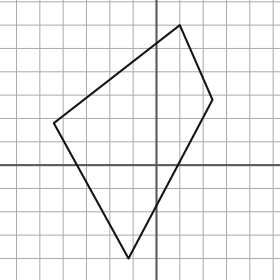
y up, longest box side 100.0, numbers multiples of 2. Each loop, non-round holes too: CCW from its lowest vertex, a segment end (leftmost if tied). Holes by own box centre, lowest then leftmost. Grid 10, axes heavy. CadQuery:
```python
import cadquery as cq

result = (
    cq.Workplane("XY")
    .moveTo(-12.0, -40.0)
    .lineTo(24.0, 28.0)
    .lineTo(10.0, 60.0)
    .lineTo(-44.0, 18.0)
    .close()
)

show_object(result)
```